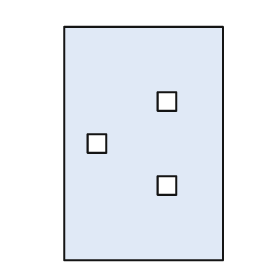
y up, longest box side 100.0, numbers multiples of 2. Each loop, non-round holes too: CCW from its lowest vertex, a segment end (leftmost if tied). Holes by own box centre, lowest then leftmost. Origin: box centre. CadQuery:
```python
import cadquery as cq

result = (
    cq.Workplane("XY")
    .moveTo(-34.0, -50.0)
    .lineTo(34.0, -50.0)
    .lineTo(34.0, 50.0)
    .lineTo(-34.0, 50.0)
    .close()
    .moveTo(6.0, -22.0)
    .lineTo(14.0, -22.0)
    .lineTo(14.0, -14.0)
    .lineTo(6.0, -14.0)
    .close()
    .moveTo(-24.0, -4.0)
    .lineTo(-16.0, -4.0)
    .lineTo(-16.0, 4.0)
    .lineTo(-24.0, 4.0)
    .close()
    .moveTo(6.0, 14.0)
    .lineTo(14.0, 14.0)
    .lineTo(14.0, 22.0)
    .lineTo(6.0, 22.0)
    .close()
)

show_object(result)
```